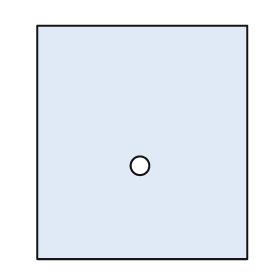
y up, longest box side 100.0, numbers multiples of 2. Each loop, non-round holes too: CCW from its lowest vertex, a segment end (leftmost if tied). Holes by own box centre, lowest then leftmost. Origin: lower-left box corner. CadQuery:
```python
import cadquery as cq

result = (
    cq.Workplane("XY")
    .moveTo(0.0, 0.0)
    .lineTo(90.0, 0.0)
    .lineTo(90.0, 100.0)
    .lineTo(0.0, 100.0)
    .close()
    .moveTo(44.0, 40.0)
    .circle(4.0)
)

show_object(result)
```